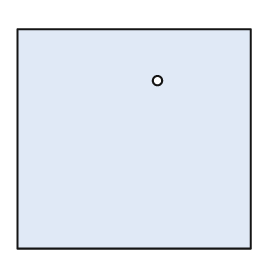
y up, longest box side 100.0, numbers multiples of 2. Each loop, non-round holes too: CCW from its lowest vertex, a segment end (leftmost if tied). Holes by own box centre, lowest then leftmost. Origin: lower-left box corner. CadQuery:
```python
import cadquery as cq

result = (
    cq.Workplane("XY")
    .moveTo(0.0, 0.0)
    .lineTo(100.0, 0.0)
    .lineTo(100.0, 94.0)
    .lineTo(0.0, 94.0)
    .close()
    .moveTo(60.0, 72.0)
    .circle(2.0)
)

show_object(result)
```